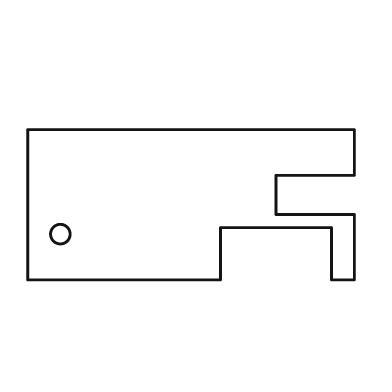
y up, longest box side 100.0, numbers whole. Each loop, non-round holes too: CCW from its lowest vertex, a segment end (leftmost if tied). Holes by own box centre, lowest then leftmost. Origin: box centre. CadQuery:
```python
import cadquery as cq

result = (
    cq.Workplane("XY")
    .moveTo(-50.0, -23.0)
    .lineTo(9.0, -23.0)
    .lineTo(9.0, -7.0)
    .lineTo(43.0, -7.0)
    .lineTo(43.0, -23.0)
    .lineTo(50.0, -23.0)
    .lineTo(50.0, -3.0)
    .lineTo(26.0, -3.0)
    .lineTo(26.0, 9.0)
    .lineTo(50.0, 9.0)
    .lineTo(50.0, 23.0)
    .lineTo(-50.0, 23.0)
    .close()
    .moveTo(-40.0, -9.0)
    .circle(3.0)
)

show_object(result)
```